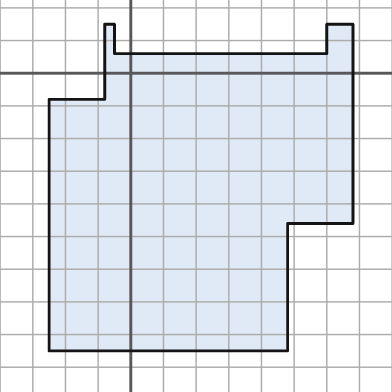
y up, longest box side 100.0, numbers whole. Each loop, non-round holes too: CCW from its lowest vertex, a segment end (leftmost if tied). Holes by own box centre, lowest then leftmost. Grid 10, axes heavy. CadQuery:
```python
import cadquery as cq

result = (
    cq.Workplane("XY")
    .moveTo(-25.0, -85.0)
    .lineTo(48.0, -85.0)
    .lineTo(48.0, -46.0)
    .lineTo(68.0, -46.0)
    .lineTo(68.0, 15.0)
    .lineTo(60.0, 15.0)
    .lineTo(60.0, 6.0)
    .lineTo(-5.0, 6.0)
    .lineTo(-5.0, 15.0)
    .lineTo(-8.0, 15.0)
    .lineTo(-8.0, -8.0)
    .lineTo(-25.0, -8.0)
    .close()
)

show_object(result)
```